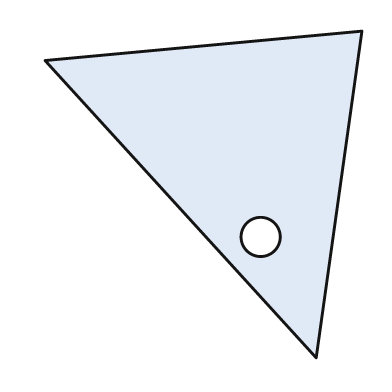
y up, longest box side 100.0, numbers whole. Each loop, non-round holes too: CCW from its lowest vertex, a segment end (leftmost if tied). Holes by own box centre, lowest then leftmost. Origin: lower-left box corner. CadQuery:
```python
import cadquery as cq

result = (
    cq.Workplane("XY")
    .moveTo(83.0, 0.0)
    .lineTo(97.0, 100.0)
    .lineTo(0.0, 91.0)
    .close()
    .moveTo(66.0, 37.0)
    .circle(6.0)
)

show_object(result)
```